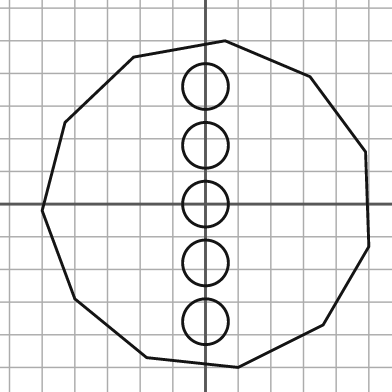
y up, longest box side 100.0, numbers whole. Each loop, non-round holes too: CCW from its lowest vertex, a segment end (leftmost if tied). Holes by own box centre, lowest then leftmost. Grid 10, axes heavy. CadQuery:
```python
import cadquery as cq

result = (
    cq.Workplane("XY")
    .moveTo(10.0, -50.0)
    .lineTo(36.0, -37.0)
    .lineTo(50.0, -13.0)
    .lineTo(49.0, 16.0)
    .lineTo(32.0, 39.0)
    .lineTo(6.0, 50.0)
    .lineTo(-22.0, 45.0)
    .lineTo(-43.0, 25.0)
    .lineTo(-50.0, -2.0)
    .lineTo(-40.0, -29.0)
    .lineTo(-18.0, -47.0)
    .close()
    .moveTo(0.0, -36.0)
    .circle(7.0)
    .moveTo(0.0, -18.0)
    .circle(7.0)
    .moveTo(0.0, 0.0)
    .circle(7.0)
    .moveTo(0.0, 18.0)
    .circle(7.0)
    .moveTo(0.0, 36.0)
    .circle(7.0)
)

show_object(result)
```